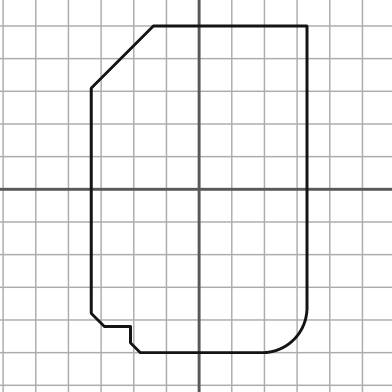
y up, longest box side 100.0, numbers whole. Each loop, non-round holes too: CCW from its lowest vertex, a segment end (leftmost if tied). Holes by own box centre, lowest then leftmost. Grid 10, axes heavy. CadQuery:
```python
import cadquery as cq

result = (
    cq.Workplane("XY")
    .moveTo(-18.0, -50.0)
    .lineTo(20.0, -50.0)
    .threePointArc((29.0, -46.0), (33.0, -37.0))
    .lineTo(33.0, 50.0)
    .lineTo(-14.0, 50.0)
    .lineTo(-33.0, 31.0)
    .lineTo(-33.0, -38.0)
    .lineTo(-29.0, -42.0)
    .lineTo(-21.0, -42.0)
    .lineTo(-21.0, -47.0)
    .close()
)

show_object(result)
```